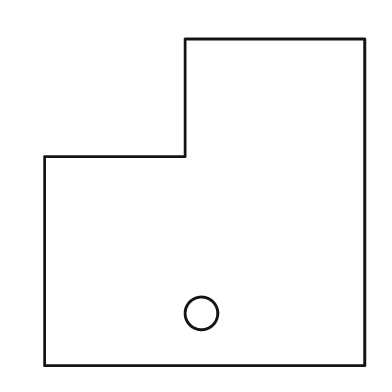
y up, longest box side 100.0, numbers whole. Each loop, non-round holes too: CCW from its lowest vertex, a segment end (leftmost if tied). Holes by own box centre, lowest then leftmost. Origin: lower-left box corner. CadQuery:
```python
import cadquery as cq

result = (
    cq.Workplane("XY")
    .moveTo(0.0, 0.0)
    .lineTo(98.0, 0.0)
    .lineTo(98.0, 100.0)
    .lineTo(43.0, 100.0)
    .lineTo(43.0, 64.0)
    .lineTo(0.0, 64.0)
    .close()
    .moveTo(48.0, 16.0)
    .circle(5.0)
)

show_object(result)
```